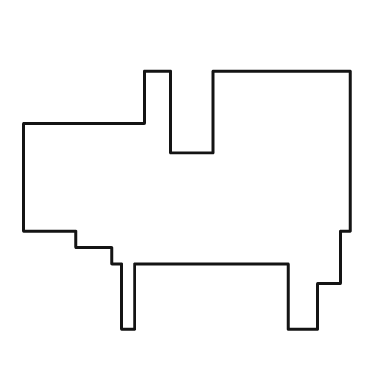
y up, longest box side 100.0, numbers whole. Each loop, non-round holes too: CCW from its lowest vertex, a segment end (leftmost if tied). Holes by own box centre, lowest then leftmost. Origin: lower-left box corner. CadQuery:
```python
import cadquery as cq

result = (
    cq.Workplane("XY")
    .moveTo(30.0, 0.0)
    .lineTo(34.0, 0.0)
    .lineTo(34.0, 20.0)
    .lineTo(81.0, 20.0)
    .lineTo(81.0, 0.0)
    .lineTo(90.0, 0.0)
    .lineTo(90.0, 14.0)
    .lineTo(97.0, 14.0)
    .lineTo(97.0, 30.0)
    .lineTo(100.0, 30.0)
    .lineTo(100.0, 79.0)
    .lineTo(58.0, 79.0)
    .lineTo(58.0, 54.0)
    .lineTo(45.0, 54.0)
    .lineTo(45.0, 79.0)
    .lineTo(37.0, 79.0)
    .lineTo(37.0, 63.0)
    .lineTo(0.0, 63.0)
    .lineTo(0.0, 30.0)
    .lineTo(16.0, 30.0)
    .lineTo(16.0, 25.0)
    .lineTo(27.0, 25.0)
    .lineTo(27.0, 20.0)
    .lineTo(30.0, 20.0)
    .close()
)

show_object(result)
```